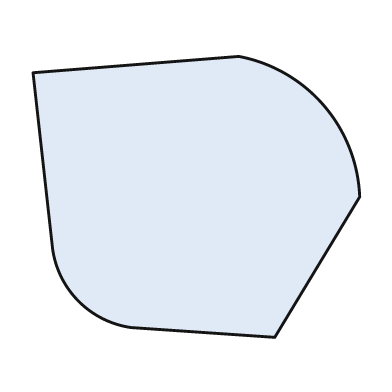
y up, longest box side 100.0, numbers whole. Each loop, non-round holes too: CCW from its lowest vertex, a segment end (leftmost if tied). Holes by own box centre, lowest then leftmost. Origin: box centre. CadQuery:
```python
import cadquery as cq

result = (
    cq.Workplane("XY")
    .moveTo(24.0, -43.0)
    .lineTo(50.0, 0.0)
    .threePointArc((39.0, 28.0), (13.0, 43.0))
    .lineTo(-50.0, 38.0)
    .lineTo(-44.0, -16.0)
    .threePointArc((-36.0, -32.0), (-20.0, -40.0))
    .close()
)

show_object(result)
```